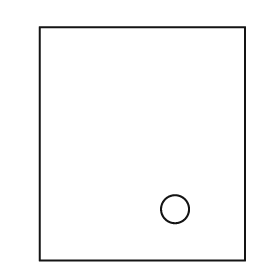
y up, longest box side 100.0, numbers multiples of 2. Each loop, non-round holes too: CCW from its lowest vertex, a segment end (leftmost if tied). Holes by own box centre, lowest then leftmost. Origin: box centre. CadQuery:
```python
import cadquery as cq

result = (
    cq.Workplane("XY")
    .moveTo(-44.0, -50.0)
    .lineTo(44.0, -50.0)
    .lineTo(44.0, 50.0)
    .lineTo(-44.0, 50.0)
    .close()
    .moveTo(14.0, -28.0)
    .circle(6.0)
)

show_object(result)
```